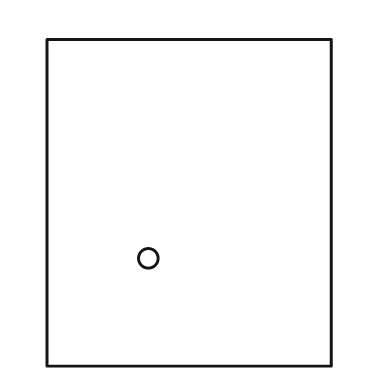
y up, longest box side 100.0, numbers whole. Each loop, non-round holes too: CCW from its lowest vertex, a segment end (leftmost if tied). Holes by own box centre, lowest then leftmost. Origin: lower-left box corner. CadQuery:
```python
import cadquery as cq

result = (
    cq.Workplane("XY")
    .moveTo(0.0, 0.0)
    .lineTo(87.0, 0.0)
    .lineTo(87.0, 100.0)
    .lineTo(0.0, 100.0)
    .close()
    .moveTo(31.0, 33.0)
    .circle(3.0)
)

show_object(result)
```